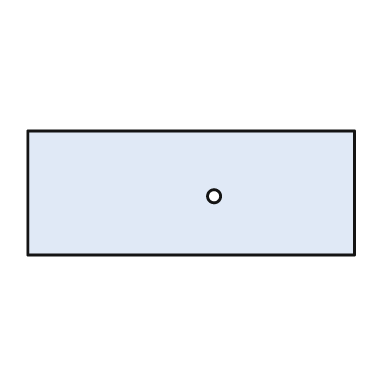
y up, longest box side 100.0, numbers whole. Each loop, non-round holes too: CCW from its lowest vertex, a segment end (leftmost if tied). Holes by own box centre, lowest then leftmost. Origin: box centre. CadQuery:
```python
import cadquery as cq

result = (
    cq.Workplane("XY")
    .moveTo(-50.0, -19.0)
    .lineTo(50.0, -19.0)
    .lineTo(50.0, 19.0)
    .lineTo(-50.0, 19.0)
    .close()
    .moveTo(7.0, -1.0)
    .circle(2.0)
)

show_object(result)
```